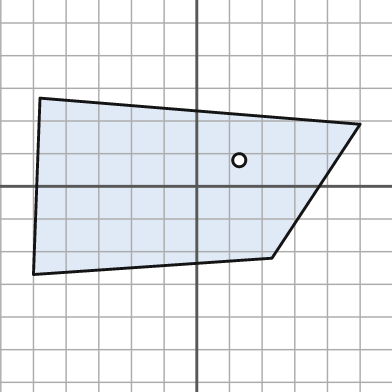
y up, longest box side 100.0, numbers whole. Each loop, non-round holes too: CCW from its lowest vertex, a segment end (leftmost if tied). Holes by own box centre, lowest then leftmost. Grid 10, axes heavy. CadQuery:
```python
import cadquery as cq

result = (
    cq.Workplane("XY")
    .moveTo(-50.0, -27.0)
    .lineTo(23.0, -22.0)
    .lineTo(50.0, 19.0)
    .lineTo(-48.0, 27.0)
    .close()
    .moveTo(13.0, 8.0)
    .circle(2.0)
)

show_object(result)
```